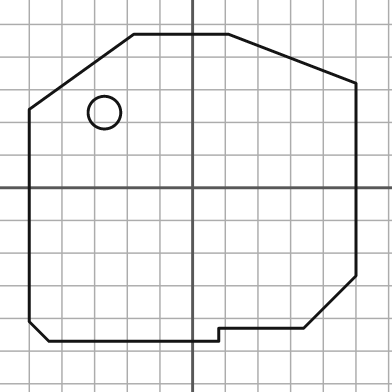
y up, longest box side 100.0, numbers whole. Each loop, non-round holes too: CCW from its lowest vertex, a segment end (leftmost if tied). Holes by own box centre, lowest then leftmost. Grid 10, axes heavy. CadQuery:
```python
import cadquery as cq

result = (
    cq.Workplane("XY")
    .moveTo(-44.0, -47.0)
    .lineTo(8.0, -47.0)
    .lineTo(8.0, -43.0)
    .lineTo(34.0, -43.0)
    .lineTo(50.0, -27.0)
    .lineTo(50.0, 32.0)
    .lineTo(11.0, 47.0)
    .lineTo(-18.0, 47.0)
    .lineTo(-50.0, 24.0)
    .lineTo(-50.0, -41.0)
    .close()
    .moveTo(-27.0, 23.0)
    .circle(5.0)
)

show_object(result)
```